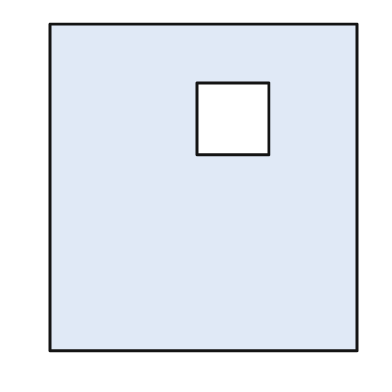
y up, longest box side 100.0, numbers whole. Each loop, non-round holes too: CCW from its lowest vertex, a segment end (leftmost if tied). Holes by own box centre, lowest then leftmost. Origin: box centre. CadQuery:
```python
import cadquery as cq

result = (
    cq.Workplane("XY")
    .moveTo(-47.0, -50.0)
    .lineTo(47.0, -50.0)
    .lineTo(47.0, 50.0)
    .lineTo(-47.0, 50.0)
    .close()
    .moveTo(-2.0, 10.0)
    .lineTo(20.0, 10.0)
    .lineTo(20.0, 32.0)
    .lineTo(-2.0, 32.0)
    .close()
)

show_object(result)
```